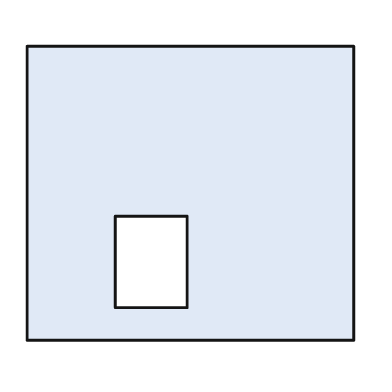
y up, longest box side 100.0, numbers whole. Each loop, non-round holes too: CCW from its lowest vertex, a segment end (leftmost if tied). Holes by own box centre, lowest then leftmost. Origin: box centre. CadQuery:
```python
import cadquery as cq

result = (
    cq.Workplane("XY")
    .moveTo(-50.0, -45.0)
    .lineTo(50.0, -45.0)
    .lineTo(50.0, 45.0)
    .lineTo(-50.0, 45.0)
    .close()
    .moveTo(-23.0, -35.0)
    .lineTo(-1.0, -35.0)
    .lineTo(-1.0, -7.0)
    .lineTo(-23.0, -7.0)
    .close()
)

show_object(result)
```